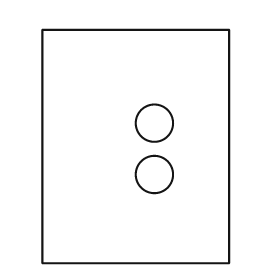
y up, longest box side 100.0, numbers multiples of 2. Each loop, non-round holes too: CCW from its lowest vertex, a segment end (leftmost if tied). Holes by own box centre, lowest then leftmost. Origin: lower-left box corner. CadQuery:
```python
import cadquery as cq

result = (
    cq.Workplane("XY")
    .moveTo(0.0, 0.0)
    .lineTo(80.0, 0.0)
    .lineTo(80.0, 100.0)
    .lineTo(0.0, 100.0)
    .close()
    .moveTo(48.0, 38.0)
    .circle(8.0)
    .moveTo(48.0, 60.0)
    .circle(8.0)
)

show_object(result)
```